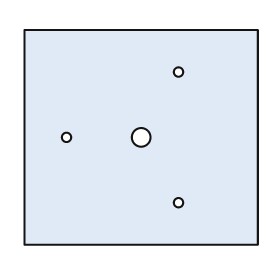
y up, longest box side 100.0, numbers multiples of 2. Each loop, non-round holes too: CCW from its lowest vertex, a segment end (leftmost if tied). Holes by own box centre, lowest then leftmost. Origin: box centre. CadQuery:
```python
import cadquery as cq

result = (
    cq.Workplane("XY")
    .moveTo(-50.0, -46.0)
    .lineTo(50.0, -46.0)
    .lineTo(50.0, 46.0)
    .lineTo(-50.0, 46.0)
    .close()
    .moveTo(16.0, -28.0)
    .circle(2.0)
    .moveTo(-32.0, 0.0)
    .circle(2.0)
    .moveTo(0.0, 0.0)
    .circle(4.0)
    .moveTo(16.0, 28.0)
    .circle(2.0)
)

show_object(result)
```